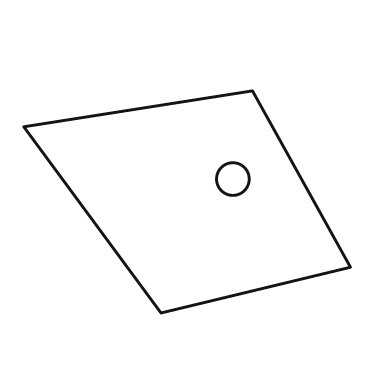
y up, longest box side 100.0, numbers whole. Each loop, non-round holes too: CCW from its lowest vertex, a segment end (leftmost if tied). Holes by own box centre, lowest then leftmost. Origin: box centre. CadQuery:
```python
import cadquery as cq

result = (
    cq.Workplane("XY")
    .moveTo(-8.0, -34.0)
    .lineTo(50.0, -20.0)
    .lineTo(20.0, 34.0)
    .lineTo(-50.0, 23.0)
    .close()
    .moveTo(14.0, 7.0)
    .circle(5.0)
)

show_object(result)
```